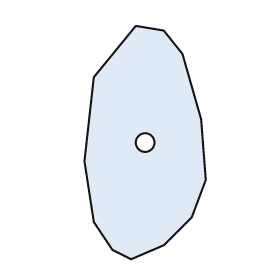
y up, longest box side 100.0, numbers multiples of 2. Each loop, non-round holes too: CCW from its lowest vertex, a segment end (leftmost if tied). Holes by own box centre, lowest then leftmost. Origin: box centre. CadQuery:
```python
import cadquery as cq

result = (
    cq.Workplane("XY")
    .moveTo(-6.0, -50.0)
    .lineTo(8.0, -44.0)
    .lineTo(20.0, -32.0)
    .lineTo(26.0, -16.0)
    .lineTo(24.0, 10.0)
    .lineTo(16.0, 38.0)
    .lineTo(8.0, 48.0)
    .lineTo(-4.0, 50.0)
    .lineTo(-22.0, 28.0)
    .lineTo(-26.0, -8.0)
    .lineTo(-22.0, -34.0)
    .lineTo(-14.0, -46.0)
    .close()
    .moveTo(0.0, 0.0)
    .circle(4.0)
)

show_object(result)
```